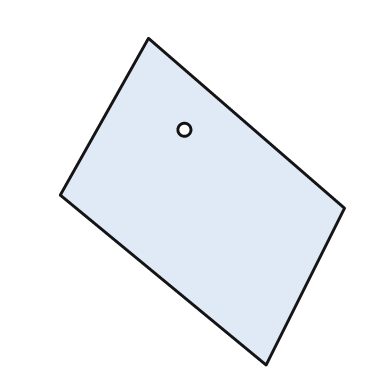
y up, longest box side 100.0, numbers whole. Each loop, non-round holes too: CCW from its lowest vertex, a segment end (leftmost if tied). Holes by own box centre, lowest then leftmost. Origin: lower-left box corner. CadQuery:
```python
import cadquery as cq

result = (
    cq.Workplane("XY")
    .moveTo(63.0, 0.0)
    .lineTo(87.0, 48.0)
    .lineTo(27.0, 100.0)
    .lineTo(0.0, 52.0)
    .close()
    .moveTo(38.0, 72.0)
    .circle(2.0)
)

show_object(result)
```